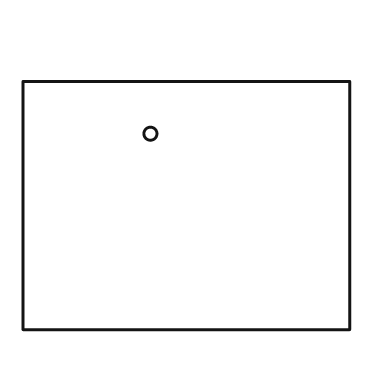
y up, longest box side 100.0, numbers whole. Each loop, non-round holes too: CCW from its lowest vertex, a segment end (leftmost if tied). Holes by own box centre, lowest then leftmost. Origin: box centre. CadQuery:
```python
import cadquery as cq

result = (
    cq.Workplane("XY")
    .moveTo(-50.0, -38.0)
    .lineTo(50.0, -38.0)
    .lineTo(50.0, 38.0)
    .lineTo(-50.0, 38.0)
    .close()
    .moveTo(-11.0, 22.0)
    .circle(2.0)
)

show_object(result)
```